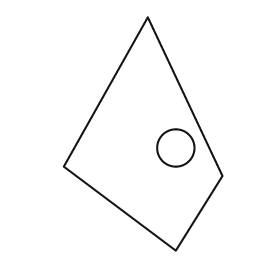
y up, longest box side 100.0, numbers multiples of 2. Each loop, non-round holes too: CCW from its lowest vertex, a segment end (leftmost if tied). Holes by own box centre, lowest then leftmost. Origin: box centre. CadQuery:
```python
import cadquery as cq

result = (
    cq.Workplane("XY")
    .moveTo(14.0, -50.0)
    .lineTo(34.0, -18.0)
    .lineTo(2.0, 50.0)
    .lineTo(-34.0, -14.0)
    .close()
    .moveTo(14.0, -6.0)
    .circle(8.0)
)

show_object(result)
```